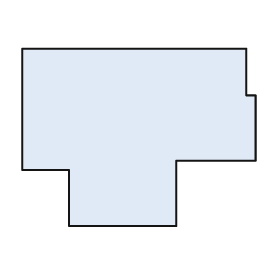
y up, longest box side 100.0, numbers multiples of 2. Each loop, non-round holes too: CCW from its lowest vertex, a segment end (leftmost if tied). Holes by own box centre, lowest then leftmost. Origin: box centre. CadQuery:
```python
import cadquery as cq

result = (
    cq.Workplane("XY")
    .moveTo(-30.0, -38.0)
    .lineTo(16.0, -38.0)
    .lineTo(16.0, -10.0)
    .lineTo(50.0, -10.0)
    .lineTo(50.0, 18.0)
    .lineTo(46.0, 18.0)
    .lineTo(46.0, 38.0)
    .lineTo(-50.0, 38.0)
    .lineTo(-50.0, -14.0)
    .lineTo(-30.0, -14.0)
    .close()
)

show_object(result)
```